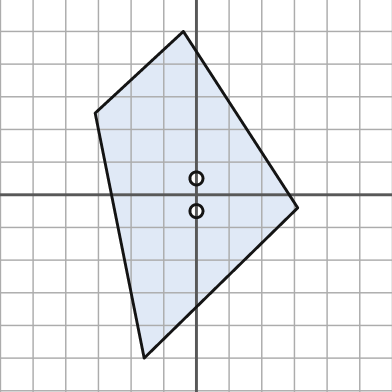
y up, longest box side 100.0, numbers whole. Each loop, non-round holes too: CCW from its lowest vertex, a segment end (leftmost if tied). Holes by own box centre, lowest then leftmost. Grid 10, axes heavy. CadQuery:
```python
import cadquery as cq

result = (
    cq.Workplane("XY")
    .moveTo(-16.0, -50.0)
    .lineTo(31.0, -4.0)
    .lineTo(-4.0, 50.0)
    .lineTo(-31.0, 25.0)
    .close()
    .moveTo(0.0, -5.0)
    .circle(2.0)
    .moveTo(0.0, 5.0)
    .circle(2.0)
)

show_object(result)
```